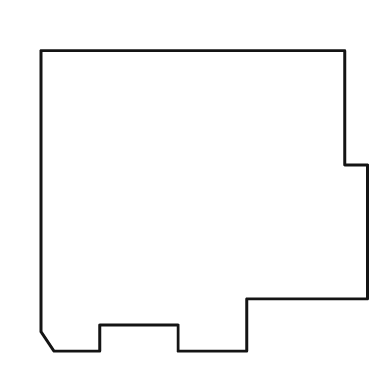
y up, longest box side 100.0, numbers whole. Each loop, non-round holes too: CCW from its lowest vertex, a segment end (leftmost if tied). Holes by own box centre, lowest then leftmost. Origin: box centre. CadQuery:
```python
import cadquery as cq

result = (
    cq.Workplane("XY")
    .moveTo(-46.0, -46.0)
    .lineTo(-32.0, -46.0)
    .lineTo(-32.0, -38.0)
    .lineTo(-8.0, -38.0)
    .lineTo(-8.0, -46.0)
    .lineTo(13.0, -46.0)
    .lineTo(13.0, -30.0)
    .lineTo(50.0, -30.0)
    .lineTo(50.0, 11.0)
    .lineTo(43.0, 11.0)
    .lineTo(43.0, 46.0)
    .lineTo(-50.0, 46.0)
    .lineTo(-50.0, -40.0)
    .close()
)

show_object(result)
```